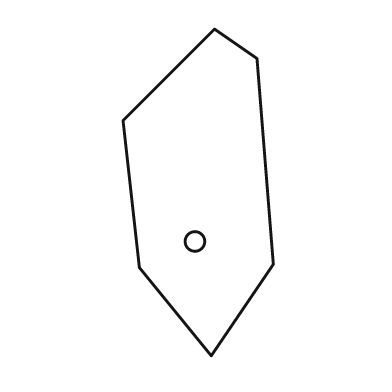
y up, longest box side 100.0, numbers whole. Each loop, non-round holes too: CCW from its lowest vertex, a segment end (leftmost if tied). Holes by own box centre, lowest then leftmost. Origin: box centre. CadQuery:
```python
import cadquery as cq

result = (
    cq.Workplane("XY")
    .moveTo(4.0, -50.0)
    .lineTo(23.0, -22.0)
    .lineTo(18.0, 41.0)
    .lineTo(5.0, 50.0)
    .lineTo(-23.0, 22.0)
    .lineTo(-18.0, -23.0)
    .close()
    .moveTo(-1.0, -15.0)
    .circle(3.0)
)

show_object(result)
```